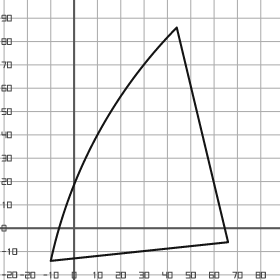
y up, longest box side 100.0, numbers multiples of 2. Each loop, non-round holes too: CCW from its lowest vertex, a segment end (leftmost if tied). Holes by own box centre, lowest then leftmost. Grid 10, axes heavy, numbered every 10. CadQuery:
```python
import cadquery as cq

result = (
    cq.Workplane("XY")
    .moveTo(-10.0, -14.0)
    .lineTo(66.0, -6.0)
    .lineTo(44.0, 86.0)
    .threePointArc((10.0, 40.0), (-10.0, -14.0))
    .close()
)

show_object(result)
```